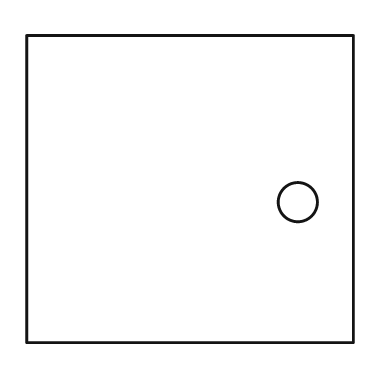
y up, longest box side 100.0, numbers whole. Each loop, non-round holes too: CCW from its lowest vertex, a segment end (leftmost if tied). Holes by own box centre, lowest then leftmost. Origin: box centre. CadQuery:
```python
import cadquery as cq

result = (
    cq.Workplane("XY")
    .moveTo(-50.0, -47.0)
    .lineTo(50.0, -47.0)
    .lineTo(50.0, 47.0)
    .lineTo(-50.0, 47.0)
    .close()
    .moveTo(33.0, -4.0)
    .circle(6.0)
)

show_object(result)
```